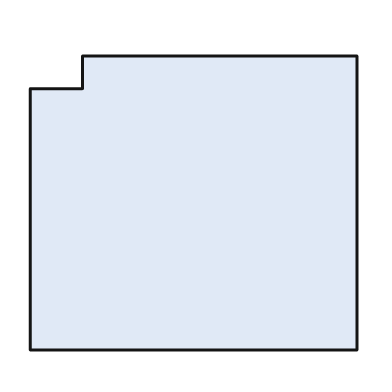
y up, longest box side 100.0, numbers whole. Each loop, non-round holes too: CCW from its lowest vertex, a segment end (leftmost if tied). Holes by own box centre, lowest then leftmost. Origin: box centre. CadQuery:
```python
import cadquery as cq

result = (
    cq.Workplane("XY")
    .moveTo(-50.0, -45.0)
    .lineTo(50.0, -45.0)
    .lineTo(50.0, 45.0)
    .lineTo(-34.0, 45.0)
    .lineTo(-34.0, 35.0)
    .lineTo(-50.0, 35.0)
    .close()
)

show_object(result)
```